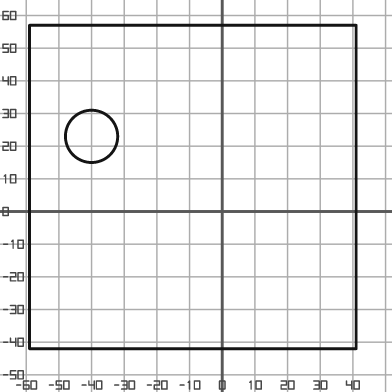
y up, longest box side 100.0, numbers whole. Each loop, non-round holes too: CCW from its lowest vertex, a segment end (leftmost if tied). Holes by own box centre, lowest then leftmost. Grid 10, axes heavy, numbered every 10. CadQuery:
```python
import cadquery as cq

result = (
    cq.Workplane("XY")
    .moveTo(-59.0, -42.0)
    .lineTo(41.0, -42.0)
    .lineTo(41.0, 57.0)
    .lineTo(-59.0, 57.0)
    .close()
    .moveTo(-40.0, 23.0)
    .circle(8.0)
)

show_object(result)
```